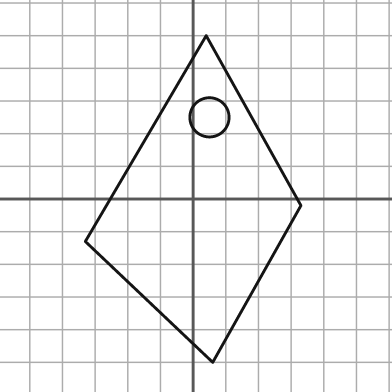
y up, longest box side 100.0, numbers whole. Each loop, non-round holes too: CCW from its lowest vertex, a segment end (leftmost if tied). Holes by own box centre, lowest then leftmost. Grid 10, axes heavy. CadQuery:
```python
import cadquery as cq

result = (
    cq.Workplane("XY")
    .moveTo(6.0, -50.0)
    .lineTo(33.0, -2.0)
    .lineTo(4.0, 50.0)
    .lineTo(-33.0, -13.0)
    .close()
    .moveTo(5.0, 25.0)
    .circle(6.0)
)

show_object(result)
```